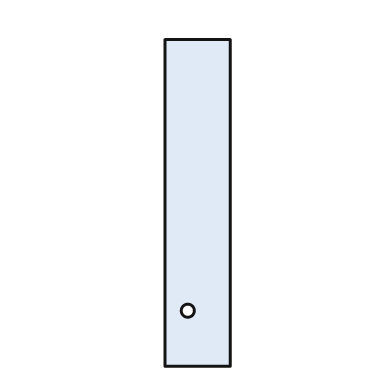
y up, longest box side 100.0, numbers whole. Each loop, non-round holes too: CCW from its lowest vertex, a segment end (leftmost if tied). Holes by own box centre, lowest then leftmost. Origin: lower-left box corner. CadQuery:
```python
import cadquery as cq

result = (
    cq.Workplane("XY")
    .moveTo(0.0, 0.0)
    .lineTo(20.0, 0.0)
    .lineTo(20.0, 100.0)
    .lineTo(0.0, 100.0)
    .close()
    .moveTo(7.0, 17.0)
    .circle(2.0)
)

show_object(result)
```